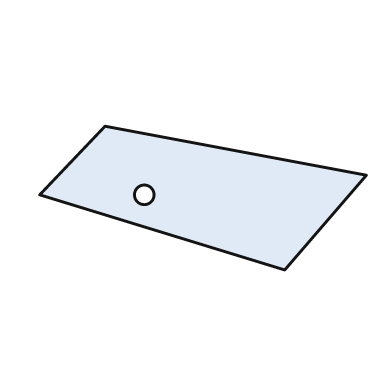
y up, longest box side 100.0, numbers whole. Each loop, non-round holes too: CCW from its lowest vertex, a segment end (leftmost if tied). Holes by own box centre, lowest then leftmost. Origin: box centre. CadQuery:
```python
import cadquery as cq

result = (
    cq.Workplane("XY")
    .moveTo(25.0, -22.0)
    .lineTo(50.0, 7.0)
    .lineTo(-30.0, 22.0)
    .lineTo(-50.0, 1.0)
    .close()
    .moveTo(-18.0, 1.0)
    .circle(3.0)
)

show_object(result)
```